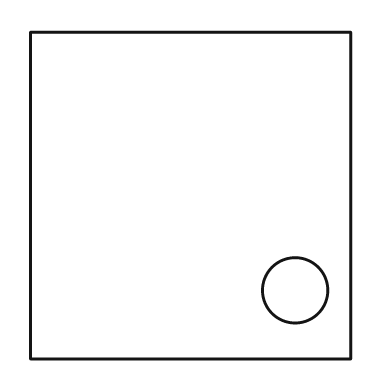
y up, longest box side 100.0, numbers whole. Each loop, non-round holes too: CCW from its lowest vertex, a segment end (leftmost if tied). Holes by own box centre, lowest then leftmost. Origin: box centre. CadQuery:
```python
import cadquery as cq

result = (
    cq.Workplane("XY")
    .moveTo(-49.0, -50.0)
    .lineTo(49.0, -50.0)
    .lineTo(49.0, 50.0)
    .lineTo(-49.0, 50.0)
    .close()
    .moveTo(32.0, -29.0)
    .circle(10.0)
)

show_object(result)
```